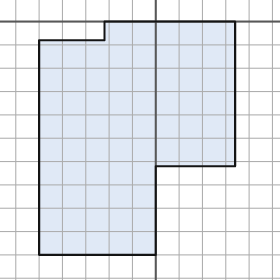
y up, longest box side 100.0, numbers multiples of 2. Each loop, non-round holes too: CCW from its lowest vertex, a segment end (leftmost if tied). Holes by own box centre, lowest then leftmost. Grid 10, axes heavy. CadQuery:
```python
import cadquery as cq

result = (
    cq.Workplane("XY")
    .moveTo(-50.0, -100.0)
    .lineTo(0.0, -100.0)
    .lineTo(0.0, -62.0)
    .lineTo(34.0, -62.0)
    .lineTo(34.0, 0.0)
    .lineTo(-22.0, 0.0)
    .lineTo(-22.0, -8.0)
    .lineTo(-50.0, -8.0)
    .close()
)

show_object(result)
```